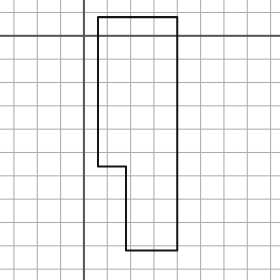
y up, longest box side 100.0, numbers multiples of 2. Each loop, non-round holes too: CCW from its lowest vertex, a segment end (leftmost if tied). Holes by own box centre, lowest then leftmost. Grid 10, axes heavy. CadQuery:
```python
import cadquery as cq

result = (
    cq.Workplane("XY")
    .moveTo(18.0, -92.0)
    .lineTo(40.0, -92.0)
    .lineTo(40.0, 8.0)
    .lineTo(6.0, 8.0)
    .lineTo(6.0, -56.0)
    .lineTo(18.0, -56.0)
    .close()
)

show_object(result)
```